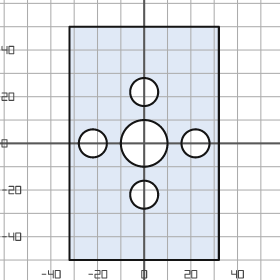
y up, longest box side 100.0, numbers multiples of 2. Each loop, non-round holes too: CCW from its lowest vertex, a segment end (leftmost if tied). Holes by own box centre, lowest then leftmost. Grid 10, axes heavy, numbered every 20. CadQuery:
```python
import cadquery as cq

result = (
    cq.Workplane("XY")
    .moveTo(-32.0, -50.0)
    .lineTo(32.0, -50.0)
    .lineTo(32.0, 50.0)
    .lineTo(-32.0, 50.0)
    .close()
    .moveTo(0.0, -22.0)
    .circle(6.0)
    .moveTo(-22.0, 0.0)
    .circle(6.0)
    .moveTo(0.0, 0.0)
    .circle(10.0)
    .moveTo(22.0, 0.0)
    .circle(6.0)
    .moveTo(0.0, 22.0)
    .circle(6.0)
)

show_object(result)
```